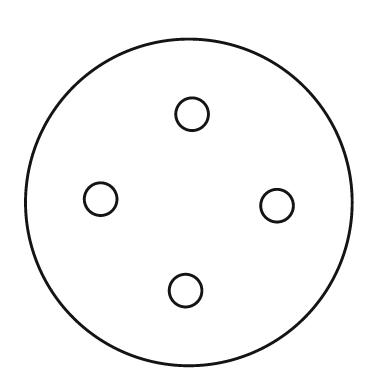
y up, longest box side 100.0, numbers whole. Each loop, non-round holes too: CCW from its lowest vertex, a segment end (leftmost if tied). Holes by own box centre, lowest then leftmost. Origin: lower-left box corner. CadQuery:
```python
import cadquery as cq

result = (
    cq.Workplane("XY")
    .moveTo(50.0, 50.0)
    .circle(50.0)
    .moveTo(49.0, 23.0)
    .circle(5.0)
    .moveTo(77.0, 49.0)
    .circle(5.0)
    .moveTo(23.0, 51.0)
    .circle(5.0)
    .moveTo(51.0, 77.0)
    .circle(5.0)
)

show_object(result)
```